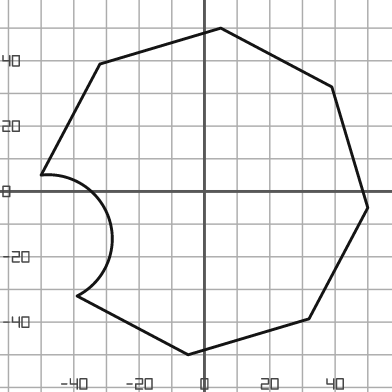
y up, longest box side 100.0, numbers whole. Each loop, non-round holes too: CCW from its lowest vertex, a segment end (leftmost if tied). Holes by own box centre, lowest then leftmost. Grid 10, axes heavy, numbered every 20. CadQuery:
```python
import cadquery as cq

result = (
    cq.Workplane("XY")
    .moveTo(-5.0, -50.0)
    .lineTo(32.0, -39.0)
    .lineTo(50.0, -5.0)
    .lineTo(39.0, 32.0)
    .lineTo(5.0, 50.0)
    .lineTo(-32.0, 39.0)
    .lineTo(-50.0, 5.0)
    .threePointArc((-29.0, -9.0), (-39.0, -32.0))
    .close()
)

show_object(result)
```